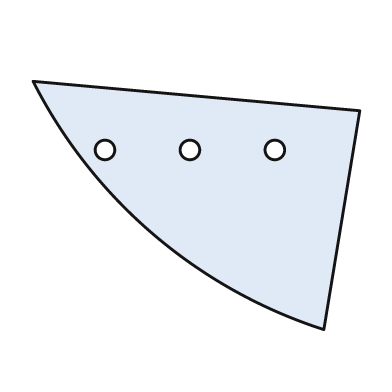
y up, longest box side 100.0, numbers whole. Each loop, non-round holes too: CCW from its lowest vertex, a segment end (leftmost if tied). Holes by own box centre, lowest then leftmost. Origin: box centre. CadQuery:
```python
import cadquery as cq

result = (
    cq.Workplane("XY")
    .moveTo(39.0, -38.0)
    .lineTo(50.0, 29.0)
    .lineTo(-50.0, 38.0)
    .threePointArc((-13.0, -9.0), (39.0, -38.0))
    .close()
    .moveTo(-28.0, 17.0)
    .circle(3.0)
    .moveTo(-2.0, 17.0)
    .circle(3.0)
    .moveTo(24.0, 17.0)
    .circle(3.0)
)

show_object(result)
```